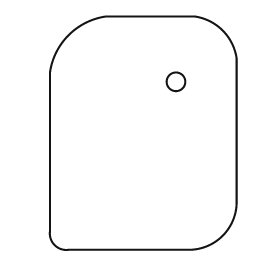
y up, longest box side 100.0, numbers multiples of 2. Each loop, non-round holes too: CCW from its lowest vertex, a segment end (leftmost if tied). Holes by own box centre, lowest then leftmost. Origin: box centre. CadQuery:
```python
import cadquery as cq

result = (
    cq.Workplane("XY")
    .moveTo(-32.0, -50.0)
    .lineTo(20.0, -50.0)
    .threePointArc((34.0, -44.0), (40.0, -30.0))
    .lineTo(40.0, 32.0)
    .threePointArc((34.0, 44.0), (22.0, 50.0))
    .lineTo(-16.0, 50.0)
    .threePointArc((-32.0, 42.0), (-40.0, 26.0))
    .lineTo(-40.0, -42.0)
    .threePointArc((-38.0, -48.0), (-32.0, -50.0))
    .close()
    .moveTo(14.0, 22.0)
    .circle(4.0)
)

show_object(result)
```